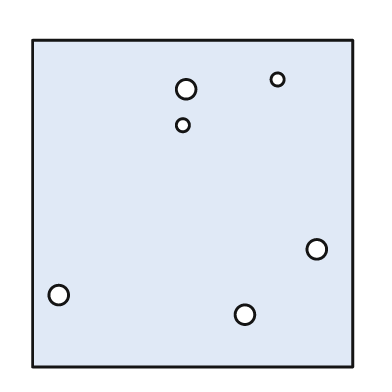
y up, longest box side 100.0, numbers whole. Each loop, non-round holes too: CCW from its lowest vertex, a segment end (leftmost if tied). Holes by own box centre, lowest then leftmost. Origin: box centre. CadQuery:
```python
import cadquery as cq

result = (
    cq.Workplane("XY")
    .moveTo(-49.0, -50.0)
    .lineTo(49.0, -50.0)
    .lineTo(49.0, 50.0)
    .lineTo(-49.0, 50.0)
    .close()
    .moveTo(16.0, -34.0)
    .circle(3.0)
    .moveTo(-41.0, -28.0)
    .circle(3.0)
    .moveTo(38.0, -14.0)
    .circle(3.0)
    .moveTo(-3.0, 24.0)
    .circle(2.0)
    .moveTo(-2.0, 35.0)
    .circle(3.0)
    .moveTo(26.0, 38.0)
    .circle(2.0)
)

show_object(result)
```